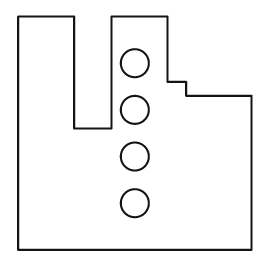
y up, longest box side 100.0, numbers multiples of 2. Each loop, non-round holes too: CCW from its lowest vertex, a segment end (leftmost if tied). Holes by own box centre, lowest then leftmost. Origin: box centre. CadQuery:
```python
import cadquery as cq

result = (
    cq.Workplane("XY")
    .moveTo(-50.0, -50.0)
    .lineTo(50.0, -50.0)
    .lineTo(50.0, 16.0)
    .lineTo(22.0, 16.0)
    .lineTo(22.0, 22.0)
    .lineTo(14.0, 22.0)
    .lineTo(14.0, 50.0)
    .lineTo(-10.0, 50.0)
    .lineTo(-10.0, 2.0)
    .lineTo(-26.0, 2.0)
    .lineTo(-26.0, 50.0)
    .lineTo(-50.0, 50.0)
    .close()
    .moveTo(0.0, -30.0)
    .circle(6.0)
    .moveTo(0.0, -10.0)
    .circle(6.0)
    .moveTo(0.0, 10.0)
    .circle(6.0)
    .moveTo(0.0, 30.0)
    .circle(6.0)
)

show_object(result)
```